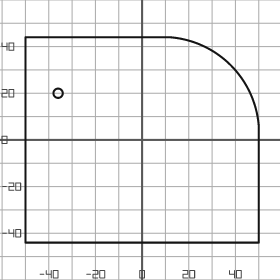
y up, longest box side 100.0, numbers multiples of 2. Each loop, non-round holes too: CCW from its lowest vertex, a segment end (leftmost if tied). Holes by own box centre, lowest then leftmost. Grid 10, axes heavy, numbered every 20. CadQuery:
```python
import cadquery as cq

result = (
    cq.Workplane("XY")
    .moveTo(-50.0, -44.0)
    .lineTo(50.0, -44.0)
    .lineTo(50.0, 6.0)
    .threePointArc((38.0, 32.0), (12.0, 44.0))
    .lineTo(-50.0, 44.0)
    .close()
    .moveTo(-36.0, 20.0)
    .circle(2.0)
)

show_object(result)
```